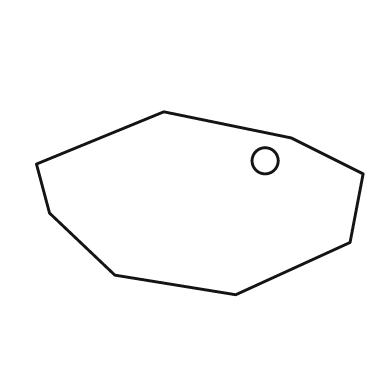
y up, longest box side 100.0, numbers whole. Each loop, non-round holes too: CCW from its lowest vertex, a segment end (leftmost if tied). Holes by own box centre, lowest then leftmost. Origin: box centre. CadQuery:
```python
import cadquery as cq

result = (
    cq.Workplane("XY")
    .moveTo(11.0, -28.0)
    .lineTo(46.0, -12.0)
    .lineTo(50.0, 9.0)
    .lineTo(28.0, 20.0)
    .lineTo(-11.0, 28.0)
    .lineTo(-50.0, 12.0)
    .lineTo(-46.0, -3.0)
    .lineTo(-26.0, -22.0)
    .close()
    .moveTo(20.0, 13.0)
    .circle(4.0)
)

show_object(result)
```